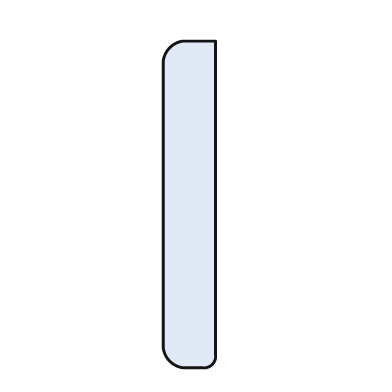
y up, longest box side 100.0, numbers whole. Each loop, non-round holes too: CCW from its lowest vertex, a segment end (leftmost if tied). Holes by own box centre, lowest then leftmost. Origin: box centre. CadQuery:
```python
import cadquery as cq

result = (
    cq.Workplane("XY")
    .moveTo(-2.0, -50.0)
    .lineTo(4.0, -50.0)
    .threePointArc((7.0, -49.0), (8.0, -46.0))
    .lineTo(8.0, 50.0)
    .lineTo(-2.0, 50.0)
    .threePointArc((-6.0, 48.0), (-8.0, 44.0))
    .lineTo(-8.0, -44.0)
    .threePointArc((-6.0, -48.0), (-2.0, -50.0))
    .close()
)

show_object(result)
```